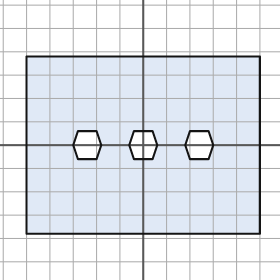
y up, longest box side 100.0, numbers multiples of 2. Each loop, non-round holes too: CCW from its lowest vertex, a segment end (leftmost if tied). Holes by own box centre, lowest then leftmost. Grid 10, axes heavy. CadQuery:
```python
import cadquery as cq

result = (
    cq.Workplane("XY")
    .moveTo(-50.0, -38.0)
    .lineTo(50.0, -38.0)
    .lineTo(50.0, 38.0)
    .lineTo(-50.0, 38.0)
    .close()
    .moveTo(-28.0, -6.0)
    .lineTo(-20.0, -6.0)
    .lineTo(-18.0, 0.0)
    .lineTo(-20.0, 6.0)
    .lineTo(-28.0, 6.0)
    .lineTo(-30.0, 0.0)
    .close()
    .moveTo(-4.0, -6.0)
    .lineTo(4.0, -6.0)
    .lineTo(6.0, 0.0)
    .lineTo(4.0, 6.0)
    .lineTo(-4.0, 6.0)
    .lineTo(-6.0, 0.0)
    .close()
    .moveTo(20.0, -6.0)
    .lineTo(28.0, -6.0)
    .lineTo(30.0, 0.0)
    .lineTo(28.0, 6.0)
    .lineTo(20.0, 6.0)
    .lineTo(18.0, 0.0)
    .close()
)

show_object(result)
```